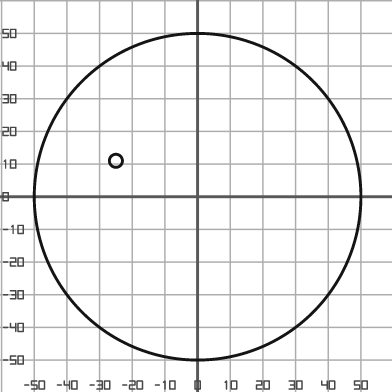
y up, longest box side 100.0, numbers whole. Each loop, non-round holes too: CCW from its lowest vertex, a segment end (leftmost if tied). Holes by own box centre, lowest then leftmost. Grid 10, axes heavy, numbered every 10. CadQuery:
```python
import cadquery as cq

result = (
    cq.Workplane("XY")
    .moveTo(0.0, 0.0)
    .circle(50.0)
    .moveTo(-25.0, 11.0)
    .circle(2.0)
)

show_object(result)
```